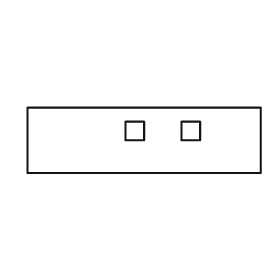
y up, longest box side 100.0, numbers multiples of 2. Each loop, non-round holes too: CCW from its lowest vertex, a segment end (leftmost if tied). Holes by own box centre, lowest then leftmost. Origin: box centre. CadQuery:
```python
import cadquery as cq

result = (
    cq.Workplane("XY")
    .moveTo(-50.0, -14.0)
    .lineTo(50.0, -14.0)
    .lineTo(50.0, 14.0)
    .lineTo(-50.0, 14.0)
    .close()
    .moveTo(-8.0, 0.0)
    .lineTo(0.0, 0.0)
    .lineTo(0.0, 8.0)
    .lineTo(-8.0, 8.0)
    .close()
    .moveTo(16.0, 0.0)
    .lineTo(24.0, 0.0)
    .lineTo(24.0, 8.0)
    .lineTo(16.0, 8.0)
    .close()
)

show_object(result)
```